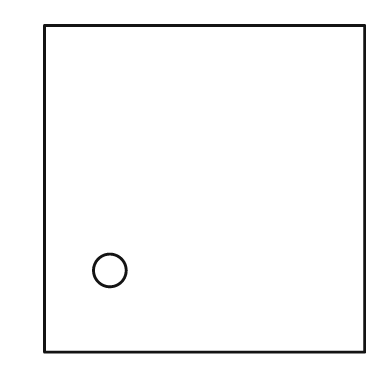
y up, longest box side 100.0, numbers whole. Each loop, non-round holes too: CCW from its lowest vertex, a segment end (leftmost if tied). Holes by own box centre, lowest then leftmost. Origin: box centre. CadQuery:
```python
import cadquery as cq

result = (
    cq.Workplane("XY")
    .moveTo(-49.0, -50.0)
    .lineTo(49.0, -50.0)
    .lineTo(49.0, 50.0)
    .lineTo(-49.0, 50.0)
    .close()
    .moveTo(-29.0, -25.0)
    .circle(5.0)
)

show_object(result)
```